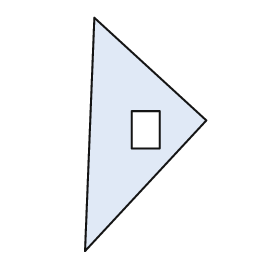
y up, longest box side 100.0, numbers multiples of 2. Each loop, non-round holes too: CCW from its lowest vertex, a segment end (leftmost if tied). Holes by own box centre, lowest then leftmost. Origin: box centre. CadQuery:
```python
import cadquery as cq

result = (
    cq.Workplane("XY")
    .moveTo(-26.0, -50.0)
    .lineTo(26.0, 6.0)
    .lineTo(-22.0, 50.0)
    .close()
    .moveTo(-6.0, -6.0)
    .lineTo(6.0, -6.0)
    .lineTo(6.0, 10.0)
    .lineTo(-6.0, 10.0)
    .close()
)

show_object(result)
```